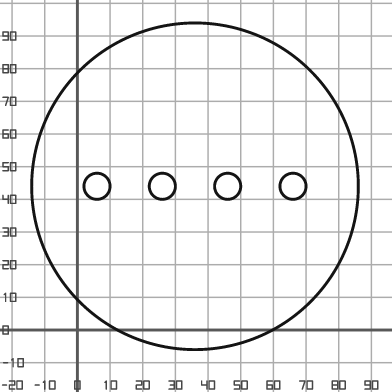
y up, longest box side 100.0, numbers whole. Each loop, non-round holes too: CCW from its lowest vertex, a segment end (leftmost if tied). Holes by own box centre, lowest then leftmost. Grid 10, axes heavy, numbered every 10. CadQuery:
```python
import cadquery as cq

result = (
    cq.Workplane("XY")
    .moveTo(36.0, 44.0)
    .circle(50.0)
    .moveTo(6.0, 44.0)
    .circle(4.0)
    .moveTo(26.0, 44.0)
    .circle(4.0)
    .moveTo(46.0, 44.0)
    .circle(4.0)
    .moveTo(66.0, 44.0)
    .circle(4.0)
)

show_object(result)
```